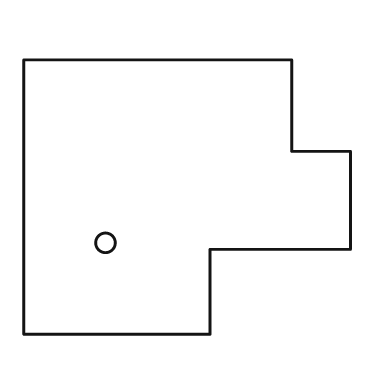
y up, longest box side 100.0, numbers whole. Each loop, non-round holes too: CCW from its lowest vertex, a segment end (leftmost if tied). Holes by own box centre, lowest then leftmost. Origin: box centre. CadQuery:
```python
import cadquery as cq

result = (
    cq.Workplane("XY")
    .moveTo(-50.0, -42.0)
    .lineTo(7.0, -42.0)
    .lineTo(7.0, -16.0)
    .lineTo(50.0, -16.0)
    .lineTo(50.0, 14.0)
    .lineTo(32.0, 14.0)
    .lineTo(32.0, 42.0)
    .lineTo(-50.0, 42.0)
    .close()
    .moveTo(-25.0, -14.0)
    .circle(3.0)
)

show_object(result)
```